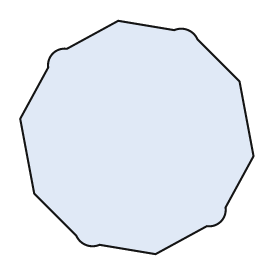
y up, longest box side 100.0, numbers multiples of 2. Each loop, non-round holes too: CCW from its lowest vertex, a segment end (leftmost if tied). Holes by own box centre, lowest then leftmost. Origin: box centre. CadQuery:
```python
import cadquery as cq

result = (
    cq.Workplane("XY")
    .moveTo(8.0, -50.0)
    .lineTo(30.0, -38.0)
    .threePointArc((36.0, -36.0), (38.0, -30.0))
    .lineTo(50.0, -8.0)
    .lineTo(44.0, 24.0)
    .lineTo(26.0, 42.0)
    .threePointArc((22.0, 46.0), (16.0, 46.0))
    .lineTo(-8.0, 50.0)
    .lineTo(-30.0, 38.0)
    .threePointArc((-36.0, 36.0), (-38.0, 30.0))
    .lineTo(-50.0, 8.0)
    .lineTo(-44.0, -24.0)
    .lineTo(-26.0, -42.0)
    .threePointArc((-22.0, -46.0), (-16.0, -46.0))
    .close()
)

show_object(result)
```